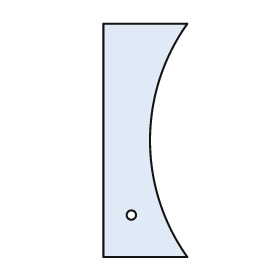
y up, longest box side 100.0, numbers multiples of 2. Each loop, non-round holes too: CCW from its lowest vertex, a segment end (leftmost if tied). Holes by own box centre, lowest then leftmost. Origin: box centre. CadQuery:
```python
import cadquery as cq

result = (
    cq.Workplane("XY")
    .moveTo(-18.0, -50.0)
    .lineTo(18.0, -50.0)
    .threePointArc((2.0, 0.0), (18.0, 50.0))
    .lineTo(-18.0, 50.0)
    .close()
    .moveTo(-6.0, -32.0)
    .circle(2.0)
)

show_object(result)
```